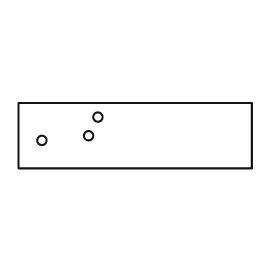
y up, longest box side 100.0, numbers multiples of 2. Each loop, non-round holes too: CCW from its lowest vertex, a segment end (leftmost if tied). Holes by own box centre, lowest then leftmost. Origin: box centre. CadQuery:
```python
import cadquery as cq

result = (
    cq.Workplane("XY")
    .moveTo(-50.0, -14.0)
    .lineTo(50.0, -14.0)
    .lineTo(50.0, 14.0)
    .lineTo(-50.0, 14.0)
    .close()
    .moveTo(-40.0, -2.0)
    .circle(2.0)
    .moveTo(-20.0, 0.0)
    .circle(2.0)
    .moveTo(-16.0, 8.0)
    .circle(2.0)
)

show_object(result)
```